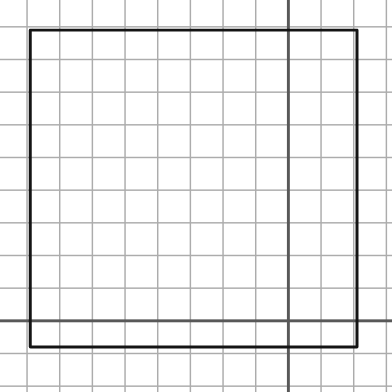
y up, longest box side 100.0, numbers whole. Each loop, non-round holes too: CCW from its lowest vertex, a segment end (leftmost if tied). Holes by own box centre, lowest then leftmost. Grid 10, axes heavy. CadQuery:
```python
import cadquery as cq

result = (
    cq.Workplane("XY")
    .moveTo(-79.0, -8.0)
    .lineTo(21.0, -8.0)
    .lineTo(21.0, 89.0)
    .lineTo(-79.0, 89.0)
    .close()
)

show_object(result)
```